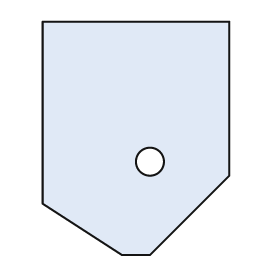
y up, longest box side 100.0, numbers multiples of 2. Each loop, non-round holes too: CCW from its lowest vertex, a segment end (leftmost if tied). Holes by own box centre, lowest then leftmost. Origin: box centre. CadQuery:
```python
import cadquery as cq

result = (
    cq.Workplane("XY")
    .moveTo(-6.0, -50.0)
    .lineTo(6.0, -50.0)
    .lineTo(40.0, -16.0)
    .lineTo(40.0, 50.0)
    .lineTo(-40.0, 50.0)
    .lineTo(-40.0, -28.0)
    .close()
    .moveTo(6.0, -10.0)
    .circle(6.0)
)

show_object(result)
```